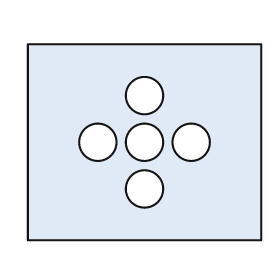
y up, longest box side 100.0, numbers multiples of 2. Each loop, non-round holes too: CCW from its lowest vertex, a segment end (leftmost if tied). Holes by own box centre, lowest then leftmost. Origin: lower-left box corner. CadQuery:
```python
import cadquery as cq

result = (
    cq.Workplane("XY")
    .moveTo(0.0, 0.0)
    .lineTo(100.0, 0.0)
    .lineTo(100.0, 84.0)
    .lineTo(0.0, 84.0)
    .close()
    .moveTo(50.0, 22.0)
    .circle(8.0)
    .moveTo(30.0, 42.0)
    .circle(8.0)
    .moveTo(50.0, 42.0)
    .circle(8.0)
    .moveTo(70.0, 42.0)
    .circle(8.0)
    .moveTo(50.0, 62.0)
    .circle(8.0)
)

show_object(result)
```